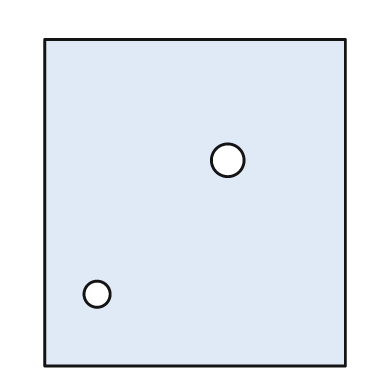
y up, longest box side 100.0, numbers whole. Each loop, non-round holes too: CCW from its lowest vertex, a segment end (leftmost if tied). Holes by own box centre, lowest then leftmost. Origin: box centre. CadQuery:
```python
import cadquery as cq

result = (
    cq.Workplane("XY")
    .moveTo(-46.0, -50.0)
    .lineTo(46.0, -50.0)
    .lineTo(46.0, 50.0)
    .lineTo(-46.0, 50.0)
    .close()
    .moveTo(-30.0, -28.0)
    .circle(4.0)
    .moveTo(10.0, 13.0)
    .circle(5.0)
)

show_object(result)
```